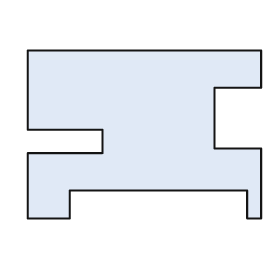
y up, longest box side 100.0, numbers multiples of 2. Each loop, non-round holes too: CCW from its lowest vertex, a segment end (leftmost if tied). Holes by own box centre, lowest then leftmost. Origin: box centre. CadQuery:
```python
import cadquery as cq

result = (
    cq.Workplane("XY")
    .moveTo(-50.0, -36.0)
    .lineTo(-32.0, -36.0)
    .lineTo(-32.0, -24.0)
    .lineTo(44.0, -24.0)
    .lineTo(44.0, -36.0)
    .lineTo(50.0, -36.0)
    .lineTo(50.0, -6.0)
    .lineTo(30.0, -6.0)
    .lineTo(30.0, 20.0)
    .lineTo(50.0, 20.0)
    .lineTo(50.0, 36.0)
    .lineTo(-50.0, 36.0)
    .lineTo(-50.0, 2.0)
    .lineTo(-18.0, 2.0)
    .lineTo(-18.0, -8.0)
    .lineTo(-50.0, -8.0)
    .close()
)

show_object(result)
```